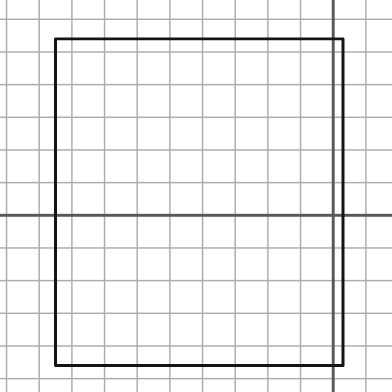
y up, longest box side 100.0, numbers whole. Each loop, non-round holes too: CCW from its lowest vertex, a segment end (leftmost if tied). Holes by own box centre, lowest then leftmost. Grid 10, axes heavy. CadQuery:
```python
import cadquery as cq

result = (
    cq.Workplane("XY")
    .moveTo(-85.0, -46.0)
    .lineTo(3.0, -46.0)
    .lineTo(3.0, 54.0)
    .lineTo(-85.0, 54.0)
    .close()
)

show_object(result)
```